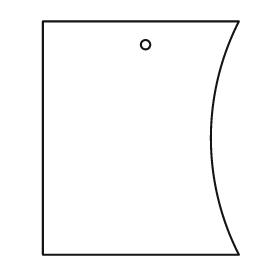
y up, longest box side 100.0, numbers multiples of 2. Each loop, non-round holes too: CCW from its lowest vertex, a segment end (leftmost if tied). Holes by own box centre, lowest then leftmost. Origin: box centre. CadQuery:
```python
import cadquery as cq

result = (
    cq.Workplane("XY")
    .moveTo(-42.0, -50.0)
    .lineTo(42.0, -50.0)
    .threePointArc((30.0, 0.0), (42.0, 50.0))
    .lineTo(-42.0, 50.0)
    .close()
    .moveTo(2.0, 40.0)
    .circle(2.0)
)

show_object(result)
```